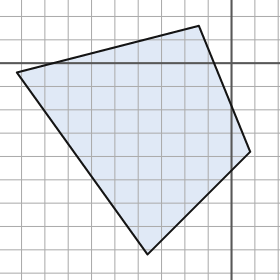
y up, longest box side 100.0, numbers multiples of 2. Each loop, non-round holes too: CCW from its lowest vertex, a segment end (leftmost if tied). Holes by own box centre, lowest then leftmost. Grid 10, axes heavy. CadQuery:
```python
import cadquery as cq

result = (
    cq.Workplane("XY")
    .moveTo(-36.0, -82.0)
    .lineTo(8.0, -38.0)
    .lineTo(-14.0, 16.0)
    .lineTo(-92.0, -4.0)
    .close()
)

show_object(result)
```